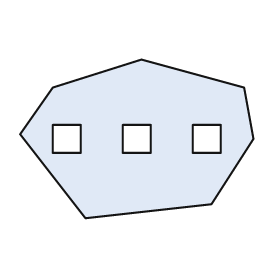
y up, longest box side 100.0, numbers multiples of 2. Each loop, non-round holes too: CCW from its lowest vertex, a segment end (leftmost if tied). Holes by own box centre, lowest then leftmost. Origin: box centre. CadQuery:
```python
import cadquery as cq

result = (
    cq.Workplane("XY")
    .moveTo(-22.0, -34.0)
    .lineTo(32.0, -28.0)
    .lineTo(50.0, 0.0)
    .lineTo(46.0, 22.0)
    .lineTo(2.0, 34.0)
    .lineTo(-36.0, 22.0)
    .lineTo(-50.0, 2.0)
    .close()
    .moveTo(-36.0, -6.0)
    .lineTo(-24.0, -6.0)
    .lineTo(-24.0, 6.0)
    .lineTo(-36.0, 6.0)
    .close()
    .moveTo(-6.0, -6.0)
    .lineTo(6.0, -6.0)
    .lineTo(6.0, 6.0)
    .lineTo(-6.0, 6.0)
    .close()
    .moveTo(24.0, -6.0)
    .lineTo(36.0, -6.0)
    .lineTo(36.0, 6.0)
    .lineTo(24.0, 6.0)
    .close()
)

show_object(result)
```